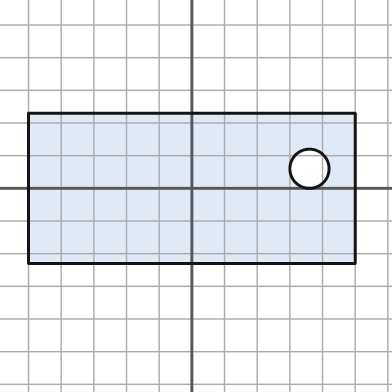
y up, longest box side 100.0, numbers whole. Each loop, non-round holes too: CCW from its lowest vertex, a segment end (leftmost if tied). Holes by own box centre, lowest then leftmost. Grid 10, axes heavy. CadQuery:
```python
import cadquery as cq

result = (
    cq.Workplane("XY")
    .moveTo(-50.0, -23.0)
    .lineTo(50.0, -23.0)
    .lineTo(50.0, 23.0)
    .lineTo(-50.0, 23.0)
    .close()
    .moveTo(36.0, 6.0)
    .circle(6.0)
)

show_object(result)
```